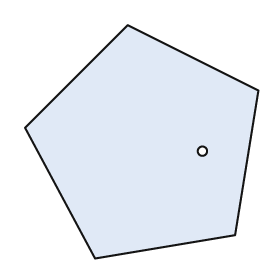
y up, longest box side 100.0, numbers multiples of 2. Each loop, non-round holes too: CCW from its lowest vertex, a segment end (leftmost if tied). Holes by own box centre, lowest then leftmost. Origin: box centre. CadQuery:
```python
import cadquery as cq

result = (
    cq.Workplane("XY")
    .moveTo(-20.0, -50.0)
    .lineTo(40.0, -40.0)
    .lineTo(50.0, 22.0)
    .lineTo(-6.0, 50.0)
    .lineTo(-50.0, 6.0)
    .close()
    .moveTo(26.0, -4.0)
    .circle(2.0)
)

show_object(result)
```